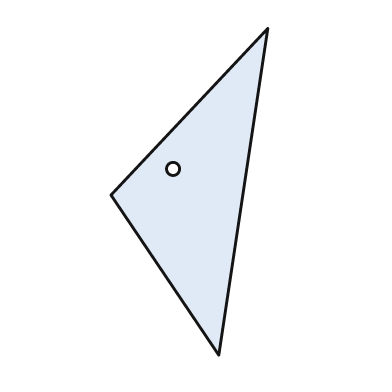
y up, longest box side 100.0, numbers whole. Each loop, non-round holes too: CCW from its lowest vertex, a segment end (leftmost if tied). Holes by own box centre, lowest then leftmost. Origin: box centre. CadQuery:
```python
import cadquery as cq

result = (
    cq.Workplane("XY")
    .moveTo(9.0, -50.0)
    .lineTo(24.0, 50.0)
    .lineTo(-24.0, -1.0)
    .close()
    .moveTo(-5.0, 7.0)
    .circle(2.0)
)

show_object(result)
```